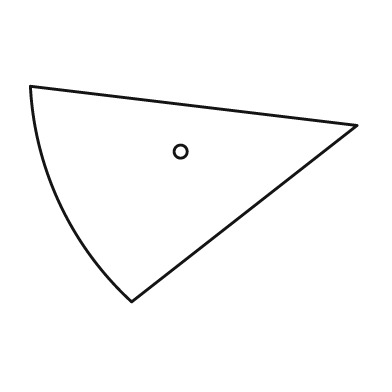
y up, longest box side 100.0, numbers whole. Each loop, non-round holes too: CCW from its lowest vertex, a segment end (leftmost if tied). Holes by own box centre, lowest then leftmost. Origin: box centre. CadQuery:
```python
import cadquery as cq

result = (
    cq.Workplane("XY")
    .moveTo(-19.0, -33.0)
    .lineTo(50.0, 21.0)
    .lineTo(-50.0, 33.0)
    .threePointArc((-41.0, -3.0), (-19.0, -33.0))
    .close()
    .moveTo(-4.0, 13.0)
    .circle(2.0)
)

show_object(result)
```